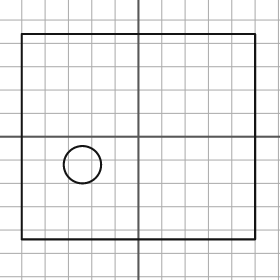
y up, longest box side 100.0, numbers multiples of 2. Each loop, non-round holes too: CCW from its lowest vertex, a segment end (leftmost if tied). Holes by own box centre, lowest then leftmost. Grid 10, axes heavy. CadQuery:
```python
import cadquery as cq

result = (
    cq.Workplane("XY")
    .moveTo(-50.0, -44.0)
    .lineTo(50.0, -44.0)
    .lineTo(50.0, 44.0)
    .lineTo(-50.0, 44.0)
    .close()
    .moveTo(-24.0, -12.0)
    .circle(8.0)
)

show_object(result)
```